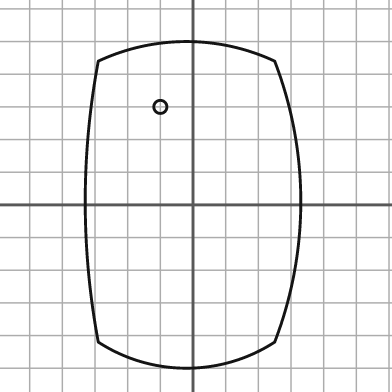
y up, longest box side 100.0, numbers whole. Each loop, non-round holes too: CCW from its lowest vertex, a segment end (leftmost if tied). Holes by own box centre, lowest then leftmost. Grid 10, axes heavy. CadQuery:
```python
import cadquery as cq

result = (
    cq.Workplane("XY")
    .moveTo(-29.0, -42.0)
    .threePointArc((-2.0, -50.0), (25.0, -42.0))
    .threePointArc((33.0, 1.0), (25.0, 44.0))
    .threePointArc((-2.0, 50.0), (-29.0, 44.0))
    .threePointArc((-33.0, 1.0), (-29.0, -42.0))
    .close()
    .moveTo(-10.0, 30.0)
    .circle(2.0)
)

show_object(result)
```